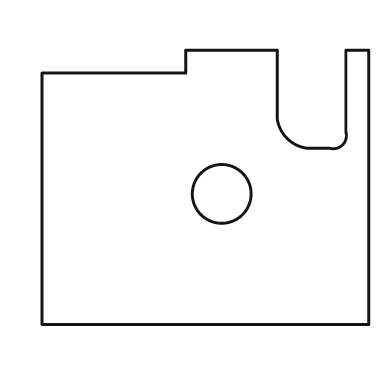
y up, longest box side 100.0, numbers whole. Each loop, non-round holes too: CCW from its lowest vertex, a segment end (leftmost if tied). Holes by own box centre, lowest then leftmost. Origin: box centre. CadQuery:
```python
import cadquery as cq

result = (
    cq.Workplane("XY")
    .moveTo(-50.0, -42.0)
    .lineTo(50.0, -42.0)
    .lineTo(50.0, 42.0)
    .lineTo(43.0, 42.0)
    .lineTo(43.0, 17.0)
    .threePointArc((42.0, 13.0), (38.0, 12.0))
    .lineTo(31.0, 12.0)
    .threePointArc((25.0, 15.0), (22.0, 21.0))
    .lineTo(22.0, 42.0)
    .lineTo(-6.0, 42.0)
    .lineTo(-6.0, 35.0)
    .lineTo(-50.0, 35.0)
    .close()
    .moveTo(5.0, -2.0)
    .circle(9.0)
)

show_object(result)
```